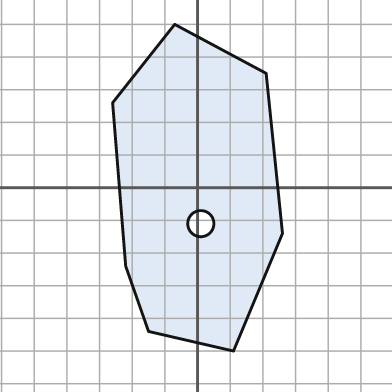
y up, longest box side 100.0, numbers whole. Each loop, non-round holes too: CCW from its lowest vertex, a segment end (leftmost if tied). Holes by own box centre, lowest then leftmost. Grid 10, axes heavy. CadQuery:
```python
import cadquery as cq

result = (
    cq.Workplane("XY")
    .moveTo(11.0, -50.0)
    .lineTo(26.0, -14.0)
    .lineTo(21.0, 35.0)
    .lineTo(-7.0, 50.0)
    .lineTo(-26.0, 26.0)
    .lineTo(-22.0, -24.0)
    .lineTo(-15.0, -44.0)
    .close()
    .moveTo(1.0, -11.0)
    .circle(4.0)
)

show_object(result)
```